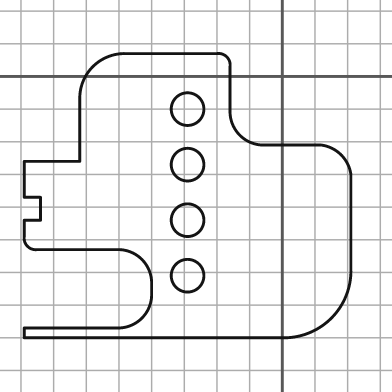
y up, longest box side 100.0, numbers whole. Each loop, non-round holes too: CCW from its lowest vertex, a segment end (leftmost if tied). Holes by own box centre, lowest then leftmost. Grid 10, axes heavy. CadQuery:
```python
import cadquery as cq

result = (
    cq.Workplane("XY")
    .moveTo(-79.0, -80.0)
    .lineTo(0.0, -80.0)
    .threePointArc((15.0, -74.0), (21.0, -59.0))
    .lineTo(21.0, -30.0)
    .threePointArc((18.0, -24.0), (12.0, -21.0))
    .lineTo(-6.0, -21.0)
    .threePointArc((-13.0, -18.0), (-16.0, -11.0))
    .lineTo(-16.0, 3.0)
    .threePointArc((-17.0, 6.0), (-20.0, 7.0))
    .lineTo(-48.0, 7.0)
    .threePointArc((-58.0, 3.0), (-62.0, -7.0))
    .lineTo(-62.0, -26.0)
    .lineTo(-79.0, -26.0)
    .lineTo(-79.0, -37.0)
    .lineTo(-74.0, -37.0)
    .lineTo(-74.0, -44.0)
    .lineTo(-79.0, -44.0)
    .lineTo(-79.0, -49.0)
    .threePointArc((-78.0, -52.0), (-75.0, -53.0))
    .lineTo(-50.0, -53.0)
    .threePointArc((-43.0, -56.0), (-40.0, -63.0))
    .lineTo(-40.0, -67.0)
    .threePointArc((-43.0, -74.0), (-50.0, -77.0))
    .lineTo(-79.0, -77.0)
    .close()
    .moveTo(-29.0, -61.0)
    .circle(5.0)
    .moveTo(-29.0, -44.0)
    .circle(5.0)
    .moveTo(-29.0, -27.0)
    .circle(5.0)
    .moveTo(-29.0, -10.0)
    .circle(5.0)
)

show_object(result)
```